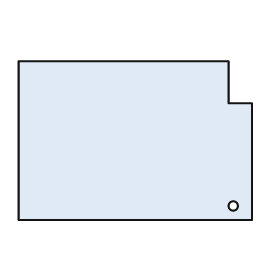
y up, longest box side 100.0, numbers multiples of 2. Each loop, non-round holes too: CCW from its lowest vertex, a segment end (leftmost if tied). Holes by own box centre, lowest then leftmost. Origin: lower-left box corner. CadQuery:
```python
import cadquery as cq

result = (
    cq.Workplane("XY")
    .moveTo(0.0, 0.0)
    .lineTo(100.0, 0.0)
    .lineTo(100.0, 50.0)
    .lineTo(90.0, 50.0)
    .lineTo(90.0, 68.0)
    .lineTo(0.0, 68.0)
    .close()
    .moveTo(92.0, 6.0)
    .circle(2.0)
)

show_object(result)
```